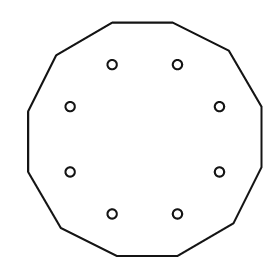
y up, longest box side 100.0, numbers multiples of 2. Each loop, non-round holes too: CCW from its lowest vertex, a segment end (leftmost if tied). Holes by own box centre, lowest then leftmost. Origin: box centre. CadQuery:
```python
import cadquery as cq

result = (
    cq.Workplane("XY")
    .moveTo(-12.0, -50.0)
    .lineTo(14.0, -50.0)
    .lineTo(38.0, -36.0)
    .lineTo(50.0, -12.0)
    .lineTo(50.0, 14.0)
    .lineTo(36.0, 38.0)
    .lineTo(12.0, 50.0)
    .lineTo(-14.0, 50.0)
    .lineTo(-38.0, 36.0)
    .lineTo(-50.0, 12.0)
    .lineTo(-50.0, -14.0)
    .lineTo(-36.0, -38.0)
    .close()
    .moveTo(-14.0, -32.0)
    .circle(2.0)
    .moveTo(14.0, -32.0)
    .circle(2.0)
    .moveTo(-32.0, -14.0)
    .circle(2.0)
    .moveTo(32.0, -14.0)
    .circle(2.0)
    .moveTo(-32.0, 14.0)
    .circle(2.0)
    .moveTo(32.0, 14.0)
    .circle(2.0)
    .moveTo(-14.0, 32.0)
    .circle(2.0)
    .moveTo(14.0, 32.0)
    .circle(2.0)
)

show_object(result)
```